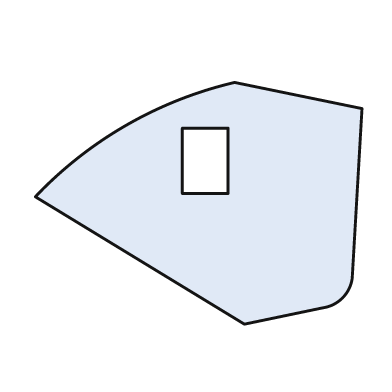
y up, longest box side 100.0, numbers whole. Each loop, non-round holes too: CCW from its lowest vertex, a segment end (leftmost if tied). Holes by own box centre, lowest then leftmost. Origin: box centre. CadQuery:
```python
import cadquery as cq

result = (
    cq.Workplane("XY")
    .moveTo(14.0, -37.0)
    .lineTo(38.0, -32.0)
    .threePointArc((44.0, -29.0), (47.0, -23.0))
    .lineTo(50.0, 29.0)
    .lineTo(11.0, 37.0)
    .threePointArc((-22.0, 24.0), (-50.0, 2.0))
    .close()
    .moveTo(-5.0, 3.0)
    .lineTo(9.0, 3.0)
    .lineTo(9.0, 23.0)
    .lineTo(-5.0, 23.0)
    .close()
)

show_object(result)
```